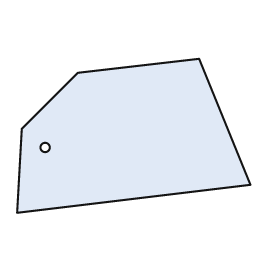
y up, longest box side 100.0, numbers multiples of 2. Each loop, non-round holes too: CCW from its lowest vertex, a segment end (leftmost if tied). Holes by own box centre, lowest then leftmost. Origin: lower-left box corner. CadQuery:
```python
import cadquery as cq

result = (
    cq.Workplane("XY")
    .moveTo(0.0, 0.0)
    .lineTo(100.0, 12.0)
    .lineTo(78.0, 66.0)
    .lineTo(26.0, 60.0)
    .lineTo(2.0, 36.0)
    .close()
    .moveTo(12.0, 28.0)
    .circle(2.0)
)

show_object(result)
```